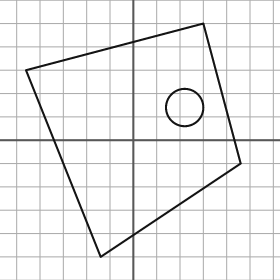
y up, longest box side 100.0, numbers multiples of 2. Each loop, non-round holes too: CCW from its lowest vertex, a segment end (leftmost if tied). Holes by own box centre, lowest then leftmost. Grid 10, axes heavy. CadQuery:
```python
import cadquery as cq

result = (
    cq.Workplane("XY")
    .moveTo(-14.0, -50.0)
    .lineTo(46.0, -10.0)
    .lineTo(30.0, 50.0)
    .lineTo(-46.0, 30.0)
    .close()
    .moveTo(22.0, 14.0)
    .circle(8.0)
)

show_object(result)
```